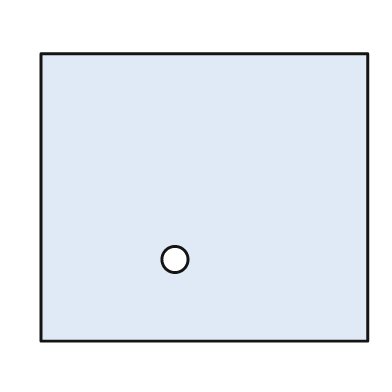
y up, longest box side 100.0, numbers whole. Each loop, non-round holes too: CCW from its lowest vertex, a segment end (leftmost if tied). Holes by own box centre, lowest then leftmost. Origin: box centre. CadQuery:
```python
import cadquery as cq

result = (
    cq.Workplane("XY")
    .moveTo(-50.0, -44.0)
    .lineTo(50.0, -44.0)
    .lineTo(50.0, 44.0)
    .lineTo(-50.0, 44.0)
    .close()
    .moveTo(-9.0, -19.0)
    .circle(4.0)
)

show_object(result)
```